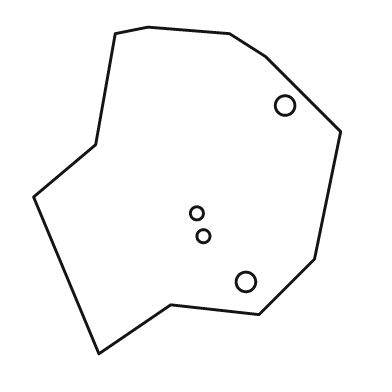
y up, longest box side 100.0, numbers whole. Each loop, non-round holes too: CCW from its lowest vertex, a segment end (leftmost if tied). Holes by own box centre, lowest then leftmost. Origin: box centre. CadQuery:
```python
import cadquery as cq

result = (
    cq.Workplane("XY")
    .moveTo(-27.0, -50.0)
    .lineTo(-5.0, -35.0)
    .lineTo(22.0, -38.0)
    .lineTo(39.0, -21.0)
    .lineTo(47.0, 18.0)
    .lineTo(24.0, 41.0)
    .lineTo(13.0, 48.0)
    .lineTo(-12.0, 50.0)
    .lineTo(-22.0, 48.0)
    .lineTo(-28.0, 14.0)
    .lineTo(-47.0, -2.0)
    .close()
    .moveTo(18.0, -28.0)
    .circle(3.0)
    .moveTo(5.0, -14.0)
    .circle(2.0)
    .moveTo(3.0, -7.0)
    .circle(2.0)
    .moveTo(30.0, 26.0)
    .circle(3.0)
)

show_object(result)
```